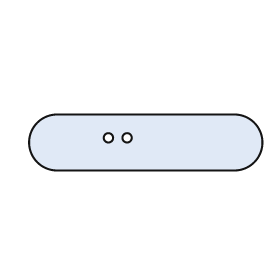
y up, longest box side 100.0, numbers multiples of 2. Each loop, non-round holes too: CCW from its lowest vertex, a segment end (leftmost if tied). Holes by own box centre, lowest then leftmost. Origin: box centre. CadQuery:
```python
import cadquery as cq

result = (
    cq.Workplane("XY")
    .moveTo(-38.0, -12.0)
    .lineTo(38.0, -12.0)
    .threePointArc((50.0, 0.0), (38.0, 12.0))
    .lineTo(-38.0, 12.0)
    .threePointArc((-50.0, 0.0), (-38.0, -12.0))
    .close()
    .moveTo(-16.0, 2.0)
    .circle(2.0)
    .moveTo(-8.0, 2.0)
    .circle(2.0)
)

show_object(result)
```